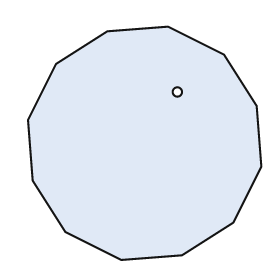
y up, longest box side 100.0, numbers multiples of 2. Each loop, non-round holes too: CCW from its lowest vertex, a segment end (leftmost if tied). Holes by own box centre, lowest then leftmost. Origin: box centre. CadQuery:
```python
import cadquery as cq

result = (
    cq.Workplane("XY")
    .moveTo(-10.0, -50.0)
    .lineTo(16.0, -48.0)
    .lineTo(38.0, -34.0)
    .lineTo(50.0, -10.0)
    .lineTo(48.0, 16.0)
    .lineTo(34.0, 38.0)
    .lineTo(10.0, 50.0)
    .lineTo(-16.0, 48.0)
    .lineTo(-38.0, 34.0)
    .lineTo(-50.0, 10.0)
    .lineTo(-48.0, -16.0)
    .lineTo(-34.0, -38.0)
    .close()
    .moveTo(14.0, 22.0)
    .circle(2.0)
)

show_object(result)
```